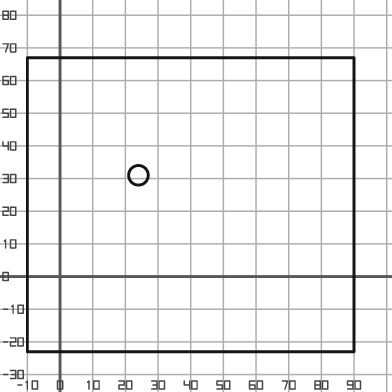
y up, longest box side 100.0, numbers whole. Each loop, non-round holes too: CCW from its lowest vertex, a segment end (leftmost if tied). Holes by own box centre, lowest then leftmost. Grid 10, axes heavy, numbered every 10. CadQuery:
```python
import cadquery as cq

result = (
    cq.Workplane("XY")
    .moveTo(-10.0, -23.0)
    .lineTo(90.0, -23.0)
    .lineTo(90.0, 67.0)
    .lineTo(-10.0, 67.0)
    .close()
    .moveTo(24.0, 31.0)
    .circle(3.0)
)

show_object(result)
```